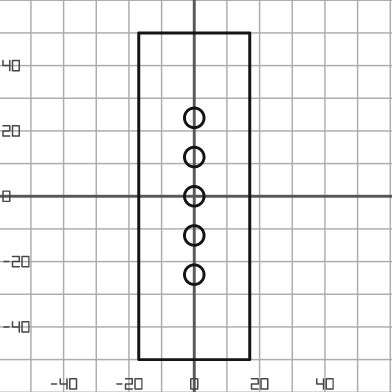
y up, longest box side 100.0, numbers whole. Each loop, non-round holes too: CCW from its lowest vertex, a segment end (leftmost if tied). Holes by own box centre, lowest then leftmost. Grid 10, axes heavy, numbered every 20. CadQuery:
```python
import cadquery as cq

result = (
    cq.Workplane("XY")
    .moveTo(-17.0, -50.0)
    .lineTo(17.0, -50.0)
    .lineTo(17.0, 50.0)
    .lineTo(-17.0, 50.0)
    .close()
    .moveTo(0.0, -24.0)
    .circle(3.0)
    .moveTo(0.0, -12.0)
    .circle(3.0)
    .moveTo(0.0, 0.0)
    .circle(3.0)
    .moveTo(0.0, 12.0)
    .circle(3.0)
    .moveTo(0.0, 24.0)
    .circle(3.0)
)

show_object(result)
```